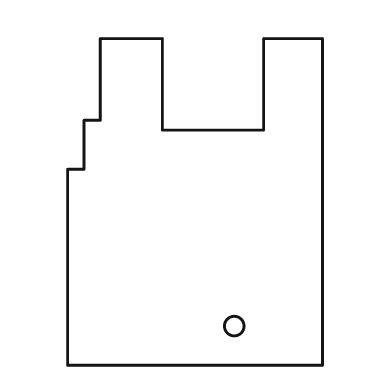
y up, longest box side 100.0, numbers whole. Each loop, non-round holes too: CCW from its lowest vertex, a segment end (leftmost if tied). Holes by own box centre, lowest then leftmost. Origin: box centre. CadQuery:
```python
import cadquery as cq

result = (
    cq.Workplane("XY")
    .moveTo(-39.0, -50.0)
    .lineTo(39.0, -50.0)
    .lineTo(39.0, 50.0)
    .lineTo(21.0, 50.0)
    .lineTo(21.0, 22.0)
    .lineTo(-10.0, 22.0)
    .lineTo(-10.0, 50.0)
    .lineTo(-29.0, 50.0)
    .lineTo(-29.0, 25.0)
    .lineTo(-34.0, 25.0)
    .lineTo(-34.0, 10.0)
    .lineTo(-39.0, 10.0)
    .close()
    .moveTo(12.0, -38.0)
    .circle(3.0)
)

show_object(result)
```